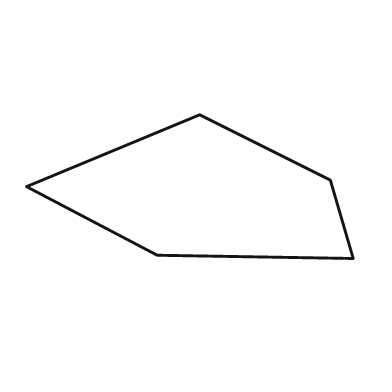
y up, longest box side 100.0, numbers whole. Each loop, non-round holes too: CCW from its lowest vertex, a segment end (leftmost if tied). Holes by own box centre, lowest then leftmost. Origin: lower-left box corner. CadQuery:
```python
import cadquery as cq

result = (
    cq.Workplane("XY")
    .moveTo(100.0, 0.0)
    .lineTo(93.0, 24.0)
    .lineTo(53.0, 44.0)
    .lineTo(0.0, 22.0)
    .lineTo(40.0, 1.0)
    .close()
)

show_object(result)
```